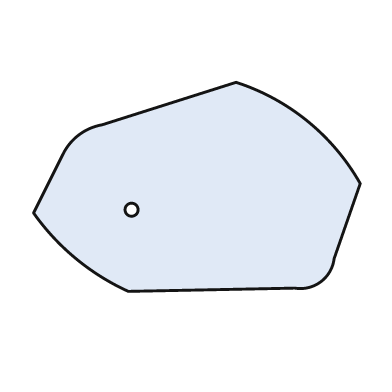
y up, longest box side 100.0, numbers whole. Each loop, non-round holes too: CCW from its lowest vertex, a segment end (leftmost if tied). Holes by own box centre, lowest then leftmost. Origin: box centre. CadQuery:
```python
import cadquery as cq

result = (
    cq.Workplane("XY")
    .moveTo(-21.0, -32.0)
    .lineTo(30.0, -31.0)
    .threePointArc((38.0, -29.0), (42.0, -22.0))
    .lineTo(50.0, 1.0)
    .threePointArc((34.0, 20.0), (12.0, 32.0))
    .lineTo(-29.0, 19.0)
    .threePointArc((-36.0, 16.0), (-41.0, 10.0))
    .lineTo(-50.0, -8.0)
    .threePointArc((-37.0, -22.0), (-21.0, -32.0))
    .close()
    .moveTo(-20.0, -7.0)
    .circle(2.0)
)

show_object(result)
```